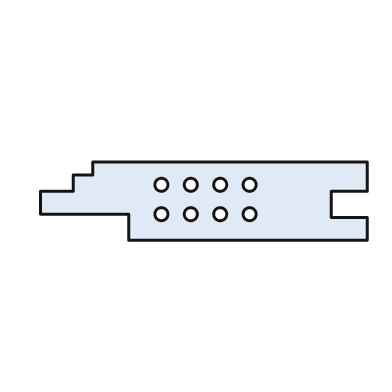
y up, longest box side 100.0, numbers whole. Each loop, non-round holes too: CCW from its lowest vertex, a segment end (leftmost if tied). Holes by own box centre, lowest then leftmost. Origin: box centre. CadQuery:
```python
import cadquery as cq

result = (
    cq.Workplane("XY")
    .moveTo(-23.0, -12.0)
    .lineTo(50.0, -12.0)
    .lineTo(50.0, -5.0)
    .lineTo(39.0, -5.0)
    .lineTo(39.0, 3.0)
    .lineTo(50.0, 3.0)
    .lineTo(50.0, 12.0)
    .lineTo(-34.0, 12.0)
    .lineTo(-34.0, 8.0)
    .lineTo(-40.0, 8.0)
    .lineTo(-40.0, 3.0)
    .lineTo(-50.0, 3.0)
    .lineTo(-50.0, -4.0)
    .lineTo(-23.0, -4.0)
    .close()
    .moveTo(-13.0, -4.0)
    .circle(2.0)
    .moveTo(-4.0, -4.0)
    .circle(2.0)
    .moveTo(5.0, -4.0)
    .circle(2.0)
    .moveTo(14.0, -4.0)
    .circle(2.0)
    .moveTo(-13.0, 5.0)
    .circle(2.0)
    .moveTo(-4.0, 5.0)
    .circle(2.0)
    .moveTo(5.0, 5.0)
    .circle(2.0)
    .moveTo(14.0, 5.0)
    .circle(2.0)
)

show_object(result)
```